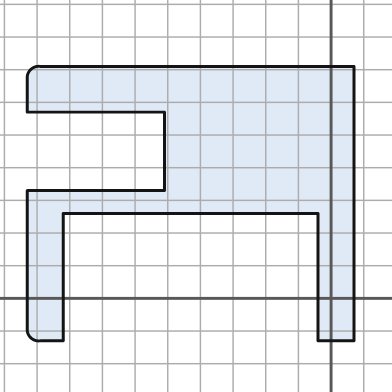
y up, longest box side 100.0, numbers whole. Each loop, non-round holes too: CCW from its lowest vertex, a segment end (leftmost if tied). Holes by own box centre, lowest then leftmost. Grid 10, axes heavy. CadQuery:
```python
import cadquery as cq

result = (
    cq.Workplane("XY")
    .moveTo(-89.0, -13.0)
    .lineTo(-82.0, -13.0)
    .lineTo(-82.0, 26.0)
    .lineTo(-4.0, 26.0)
    .lineTo(-4.0, -13.0)
    .lineTo(7.0, -13.0)
    .lineTo(7.0, 71.0)
    .lineTo(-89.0, 71.0)
    .threePointArc((-92.0, 70.0), (-93.0, 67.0))
    .lineTo(-93.0, 57.0)
    .lineTo(-51.0, 57.0)
    .lineTo(-51.0, 33.0)
    .lineTo(-93.0, 33.0)
    .lineTo(-93.0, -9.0)
    .threePointArc((-92.0, -12.0), (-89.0, -13.0))
    .close()
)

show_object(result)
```